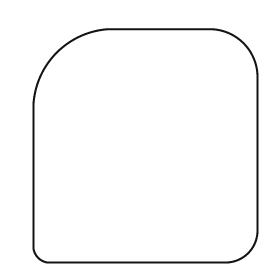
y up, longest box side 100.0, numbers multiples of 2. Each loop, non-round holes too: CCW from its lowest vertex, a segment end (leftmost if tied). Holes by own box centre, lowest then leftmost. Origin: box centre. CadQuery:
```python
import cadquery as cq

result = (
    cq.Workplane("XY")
    .moveTo(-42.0, -50.0)
    .lineTo(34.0, -50.0)
    .threePointArc((44.0, -46.0), (48.0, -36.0))
    .lineTo(48.0, 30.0)
    .threePointArc((42.0, 44.0), (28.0, 50.0))
    .lineTo(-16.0, 50.0)
    .threePointArc((-38.0, 40.0), (-48.0, 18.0))
    .lineTo(-48.0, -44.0)
    .threePointArc((-46.0, -48.0), (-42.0, -50.0))
    .close()
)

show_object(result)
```